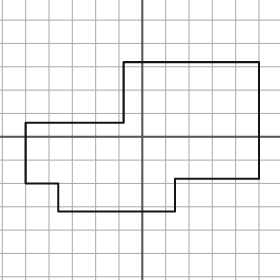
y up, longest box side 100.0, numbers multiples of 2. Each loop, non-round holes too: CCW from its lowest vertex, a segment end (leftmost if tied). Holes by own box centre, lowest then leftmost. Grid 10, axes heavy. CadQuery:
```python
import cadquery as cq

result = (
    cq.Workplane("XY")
    .moveTo(-36.0, -32.0)
    .lineTo(14.0, -32.0)
    .lineTo(14.0, -18.0)
    .lineTo(50.0, -18.0)
    .lineTo(50.0, 32.0)
    .lineTo(-8.0, 32.0)
    .lineTo(-8.0, 6.0)
    .lineTo(-50.0, 6.0)
    .lineTo(-50.0, -20.0)
    .lineTo(-36.0, -20.0)
    .close()
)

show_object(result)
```